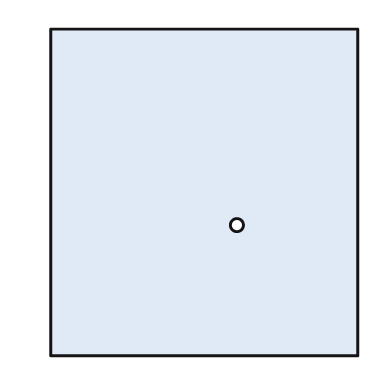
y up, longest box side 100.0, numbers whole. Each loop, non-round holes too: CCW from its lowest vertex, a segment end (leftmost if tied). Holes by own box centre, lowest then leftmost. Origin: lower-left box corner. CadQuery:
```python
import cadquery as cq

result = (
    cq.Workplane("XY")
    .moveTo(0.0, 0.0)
    .lineTo(94.0, 0.0)
    .lineTo(94.0, 100.0)
    .lineTo(0.0, 100.0)
    .close()
    .moveTo(57.0, 40.0)
    .circle(2.0)
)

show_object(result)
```